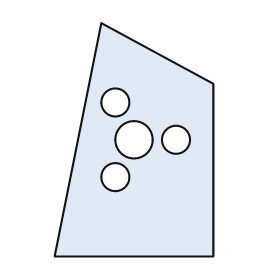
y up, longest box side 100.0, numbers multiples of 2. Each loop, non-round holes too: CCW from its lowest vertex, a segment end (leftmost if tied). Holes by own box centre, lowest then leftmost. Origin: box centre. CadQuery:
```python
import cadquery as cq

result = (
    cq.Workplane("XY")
    .moveTo(-34.0, -50.0)
    .lineTo(34.0, -50.0)
    .lineTo(34.0, 24.0)
    .lineTo(-14.0, 50.0)
    .close()
    .moveTo(-8.0, -16.0)
    .circle(6.0)
    .moveTo(0.0, 0.0)
    .circle(8.0)
    .moveTo(18.0, 0.0)
    .circle(6.0)
    .moveTo(-8.0, 16.0)
    .circle(6.0)
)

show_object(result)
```